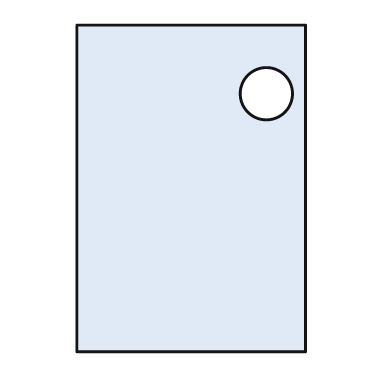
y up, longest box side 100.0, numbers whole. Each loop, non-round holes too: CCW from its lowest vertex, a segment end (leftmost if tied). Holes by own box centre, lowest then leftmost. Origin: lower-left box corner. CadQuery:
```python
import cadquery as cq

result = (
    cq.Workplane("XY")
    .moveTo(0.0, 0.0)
    .lineTo(70.0, 0.0)
    .lineTo(70.0, 100.0)
    .lineTo(0.0, 100.0)
    .close()
    .moveTo(58.0, 79.0)
    .circle(8.0)
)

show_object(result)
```